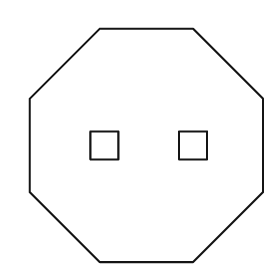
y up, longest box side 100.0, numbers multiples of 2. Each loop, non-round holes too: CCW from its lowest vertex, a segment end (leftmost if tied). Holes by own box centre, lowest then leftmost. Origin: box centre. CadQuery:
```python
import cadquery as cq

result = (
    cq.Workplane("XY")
    .moveTo(-20.0, -50.0)
    .lineTo(20.0, -50.0)
    .lineTo(50.0, -20.0)
    .lineTo(50.0, 20.0)
    .lineTo(20.0, 50.0)
    .lineTo(-20.0, 50.0)
    .lineTo(-50.0, 20.0)
    .lineTo(-50.0, -20.0)
    .close()
    .moveTo(-24.0, -6.0)
    .lineTo(-12.0, -6.0)
    .lineTo(-12.0, 6.0)
    .lineTo(-24.0, 6.0)
    .close()
    .moveTo(14.0, -6.0)
    .lineTo(26.0, -6.0)
    .lineTo(26.0, 6.0)
    .lineTo(14.0, 6.0)
    .close()
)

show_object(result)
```